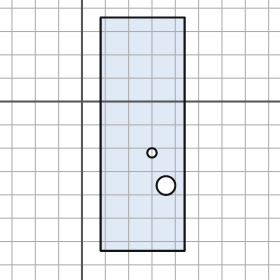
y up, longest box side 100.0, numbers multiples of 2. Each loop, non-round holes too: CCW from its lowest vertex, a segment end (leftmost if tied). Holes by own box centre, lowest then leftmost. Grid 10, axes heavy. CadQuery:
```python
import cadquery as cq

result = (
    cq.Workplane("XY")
    .moveTo(8.0, -64.0)
    .lineTo(44.0, -64.0)
    .lineTo(44.0, 36.0)
    .lineTo(8.0, 36.0)
    .close()
    .moveTo(36.0, -36.0)
    .circle(4.0)
    .moveTo(30.0, -22.0)
    .circle(2.0)
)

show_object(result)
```